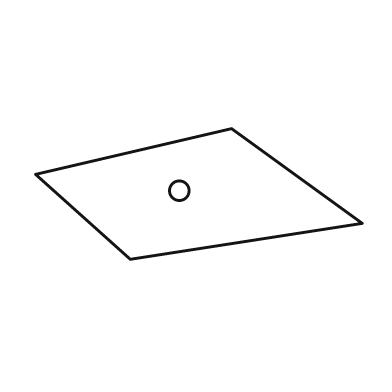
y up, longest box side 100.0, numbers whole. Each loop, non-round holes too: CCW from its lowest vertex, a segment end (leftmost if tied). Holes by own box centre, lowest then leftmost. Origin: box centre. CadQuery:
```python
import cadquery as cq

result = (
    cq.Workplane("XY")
    .moveTo(-21.0, -20.0)
    .lineTo(50.0, -9.0)
    .lineTo(10.0, 20.0)
    .lineTo(-50.0, 6.0)
    .close()
    .moveTo(-6.0, 1.0)
    .circle(3.0)
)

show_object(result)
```